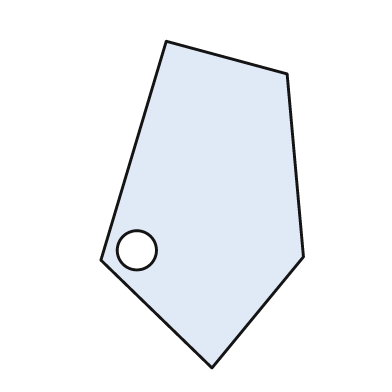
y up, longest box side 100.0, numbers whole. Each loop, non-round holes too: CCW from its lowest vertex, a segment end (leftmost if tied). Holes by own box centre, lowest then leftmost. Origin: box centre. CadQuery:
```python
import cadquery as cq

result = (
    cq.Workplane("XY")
    .moveTo(3.0, -50.0)
    .lineTo(31.0, -16.0)
    .lineTo(26.0, 40.0)
    .lineTo(-11.0, 50.0)
    .lineTo(-31.0, -17.0)
    .close()
    .moveTo(-20.0, -14.0)
    .circle(6.0)
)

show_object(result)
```